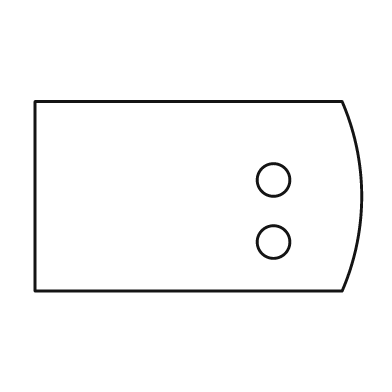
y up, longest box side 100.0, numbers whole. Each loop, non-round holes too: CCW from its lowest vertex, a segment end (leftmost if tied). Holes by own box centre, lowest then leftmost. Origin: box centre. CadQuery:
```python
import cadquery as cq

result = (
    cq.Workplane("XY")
    .moveTo(-50.0, -29.0)
    .lineTo(44.0, -29.0)
    .threePointArc((50.0, 0.0), (44.0, 29.0))
    .lineTo(-50.0, 29.0)
    .close()
    .moveTo(23.0, -14.0)
    .circle(5.0)
    .moveTo(23.0, 5.0)
    .circle(5.0)
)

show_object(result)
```